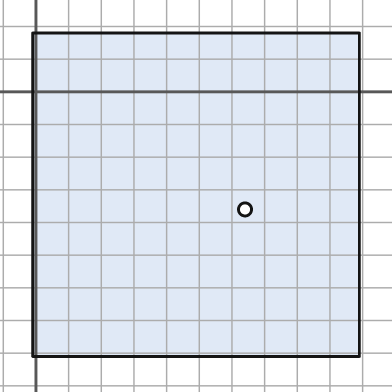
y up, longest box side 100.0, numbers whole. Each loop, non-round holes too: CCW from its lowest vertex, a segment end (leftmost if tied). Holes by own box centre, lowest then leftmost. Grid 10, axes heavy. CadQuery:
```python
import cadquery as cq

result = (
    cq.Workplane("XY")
    .moveTo(-1.0, -81.0)
    .lineTo(99.0, -81.0)
    .lineTo(99.0, 18.0)
    .lineTo(-1.0, 18.0)
    .close()
    .moveTo(64.0, -36.0)
    .circle(2.0)
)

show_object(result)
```